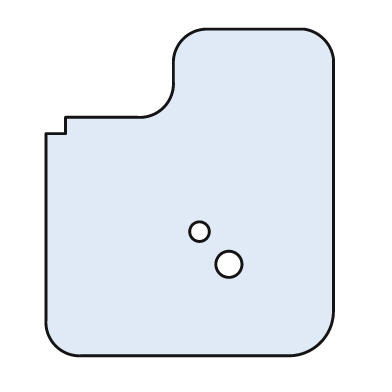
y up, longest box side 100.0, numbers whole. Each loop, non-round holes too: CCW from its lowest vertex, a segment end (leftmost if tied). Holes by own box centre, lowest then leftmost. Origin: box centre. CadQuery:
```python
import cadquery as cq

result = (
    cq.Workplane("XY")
    .moveTo(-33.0, -50.0)
    .lineTo(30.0, -50.0)
    .threePointArc((40.0, -46.0), (44.0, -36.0))
    .lineTo(44.0, 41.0)
    .threePointArc((41.0, 47.0), (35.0, 50.0))
    .lineTo(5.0, 50.0)
    .threePointArc((-2.0, 47.0), (-5.0, 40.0))
    .lineTo(-5.0, 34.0)
    .threePointArc((-8.0, 26.0), (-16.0, 23.0))
    .lineTo(-38.0, 23.0)
    .lineTo(-38.0, 18.0)
    .lineTo(-44.0, 18.0)
    .lineTo(-44.0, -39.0)
    .threePointArc((-41.0, -47.0), (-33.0, -50.0))
    .close()
    .moveTo(12.0, -22.0)
    .circle(4.0)
    .moveTo(3.0, -12.0)
    .circle(3.0)
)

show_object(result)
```